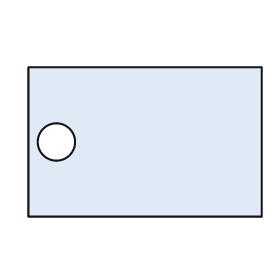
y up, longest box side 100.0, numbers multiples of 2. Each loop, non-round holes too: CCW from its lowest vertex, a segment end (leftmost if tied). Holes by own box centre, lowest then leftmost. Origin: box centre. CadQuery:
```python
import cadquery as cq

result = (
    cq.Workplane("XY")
    .moveTo(-50.0, -32.0)
    .lineTo(50.0, -32.0)
    .lineTo(50.0, 32.0)
    .lineTo(-50.0, 32.0)
    .close()
    .moveTo(-38.0, 0.0)
    .circle(8.0)
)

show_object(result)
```